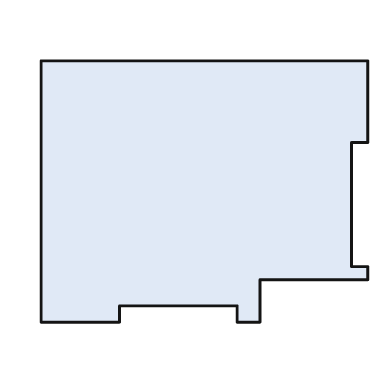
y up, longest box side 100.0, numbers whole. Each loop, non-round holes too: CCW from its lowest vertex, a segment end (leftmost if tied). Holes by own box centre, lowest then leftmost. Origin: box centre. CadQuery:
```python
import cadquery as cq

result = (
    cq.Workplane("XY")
    .moveTo(-50.0, -40.0)
    .lineTo(-26.0, -40.0)
    .lineTo(-26.0, -35.0)
    .lineTo(10.0, -35.0)
    .lineTo(10.0, -40.0)
    .lineTo(17.0, -40.0)
    .lineTo(17.0, -27.0)
    .lineTo(50.0, -27.0)
    .lineTo(50.0, -23.0)
    .lineTo(45.0, -23.0)
    .lineTo(45.0, 15.0)
    .lineTo(50.0, 15.0)
    .lineTo(50.0, 40.0)
    .lineTo(-50.0, 40.0)
    .close()
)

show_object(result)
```